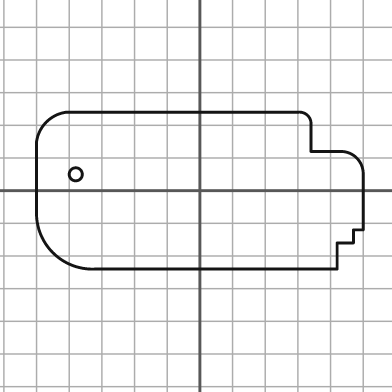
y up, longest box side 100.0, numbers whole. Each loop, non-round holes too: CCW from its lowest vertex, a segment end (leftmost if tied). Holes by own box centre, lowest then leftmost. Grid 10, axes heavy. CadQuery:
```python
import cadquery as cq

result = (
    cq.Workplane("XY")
    .moveTo(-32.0, -24.0)
    .lineTo(42.0, -24.0)
    .lineTo(42.0, -16.0)
    .lineTo(47.0, -16.0)
    .lineTo(47.0, -12.0)
    .lineTo(50.0, -12.0)
    .lineTo(50.0, 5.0)
    .threePointArc((48.0, 10.0), (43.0, 12.0))
    .lineTo(34.0, 12.0)
    .lineTo(34.0, 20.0)
    .threePointArc((33.0, 23.0), (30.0, 24.0))
    .lineTo(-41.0, 24.0)
    .threePointArc((-47.0, 21.0), (-50.0, 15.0))
    .lineTo(-50.0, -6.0)
    .threePointArc((-45.0, -19.0), (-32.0, -24.0))
    .close()
    .moveTo(-38.0, 5.0)
    .circle(2.0)
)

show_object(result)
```